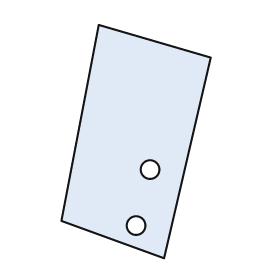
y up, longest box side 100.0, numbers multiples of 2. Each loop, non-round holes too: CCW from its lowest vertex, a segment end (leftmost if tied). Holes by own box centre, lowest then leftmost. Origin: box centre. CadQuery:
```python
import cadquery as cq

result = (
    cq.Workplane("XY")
    .moveTo(12.0, -50.0)
    .lineTo(32.0, 36.0)
    .lineTo(-16.0, 50.0)
    .lineTo(-32.0, -34.0)
    .close()
    .moveTo(0.0, -36.0)
    .circle(4.0)
    .moveTo(6.0, -12.0)
    .circle(4.0)
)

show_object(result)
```